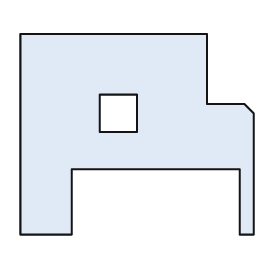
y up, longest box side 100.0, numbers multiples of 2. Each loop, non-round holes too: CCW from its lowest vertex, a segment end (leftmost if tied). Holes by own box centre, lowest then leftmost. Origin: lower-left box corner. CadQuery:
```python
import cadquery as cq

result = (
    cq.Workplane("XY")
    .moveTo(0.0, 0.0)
    .lineTo(22.0, 0.0)
    .lineTo(22.0, 28.0)
    .lineTo(94.0, 28.0)
    .lineTo(94.0, 0.0)
    .lineTo(100.0, 0.0)
    .lineTo(100.0, 52.0)
    .lineTo(96.0, 56.0)
    .lineTo(80.0, 56.0)
    .lineTo(80.0, 86.0)
    .lineTo(0.0, 86.0)
    .close()
    .moveTo(34.0, 44.0)
    .lineTo(50.0, 44.0)
    .lineTo(50.0, 60.0)
    .lineTo(34.0, 60.0)
    .close()
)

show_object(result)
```